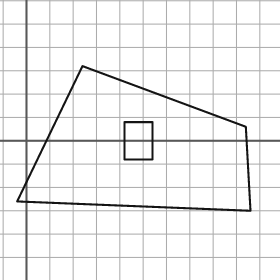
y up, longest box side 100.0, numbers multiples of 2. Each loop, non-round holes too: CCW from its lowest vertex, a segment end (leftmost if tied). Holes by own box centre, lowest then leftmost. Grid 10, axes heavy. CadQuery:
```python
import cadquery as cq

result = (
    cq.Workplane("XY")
    .moveTo(96.0, -30.0)
    .lineTo(94.0, 6.0)
    .lineTo(24.0, 32.0)
    .lineTo(-4.0, -26.0)
    .close()
    .moveTo(42.0, -8.0)
    .lineTo(54.0, -8.0)
    .lineTo(54.0, 8.0)
    .lineTo(42.0, 8.0)
    .close()
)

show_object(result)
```